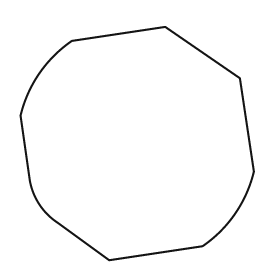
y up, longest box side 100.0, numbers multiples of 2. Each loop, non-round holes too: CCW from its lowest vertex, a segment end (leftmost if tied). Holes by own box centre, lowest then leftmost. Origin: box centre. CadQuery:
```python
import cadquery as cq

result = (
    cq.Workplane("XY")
    .moveTo(-12.0, -50.0)
    .lineTo(28.0, -44.0)
    .threePointArc((42.0, -30.0), (50.0, -12.0))
    .lineTo(44.0, 28.0)
    .lineTo(12.0, 50.0)
    .lineTo(-28.0, 44.0)
    .threePointArc((-42.0, 30.0), (-50.0, 12.0))
    .lineTo(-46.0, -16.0)
    .threePointArc((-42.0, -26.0), (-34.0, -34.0))
    .close()
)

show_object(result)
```